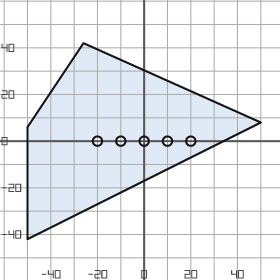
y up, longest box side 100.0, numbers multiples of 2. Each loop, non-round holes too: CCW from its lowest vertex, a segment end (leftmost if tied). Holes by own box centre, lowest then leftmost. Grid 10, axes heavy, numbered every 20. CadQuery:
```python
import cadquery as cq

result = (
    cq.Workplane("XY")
    .moveTo(-50.0, -42.0)
    .lineTo(50.0, 8.0)
    .lineTo(-26.0, 42.0)
    .lineTo(-50.0, 6.0)
    .close()
    .moveTo(-20.0, 0.0)
    .circle(2.0)
    .moveTo(-10.0, 0.0)
    .circle(2.0)
    .moveTo(0.0, 0.0)
    .circle(2.0)
    .moveTo(10.0, 0.0)
    .circle(2.0)
    .moveTo(20.0, 0.0)
    .circle(2.0)
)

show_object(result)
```